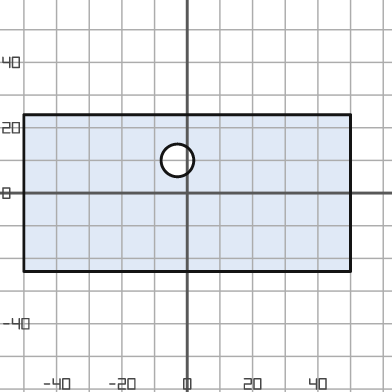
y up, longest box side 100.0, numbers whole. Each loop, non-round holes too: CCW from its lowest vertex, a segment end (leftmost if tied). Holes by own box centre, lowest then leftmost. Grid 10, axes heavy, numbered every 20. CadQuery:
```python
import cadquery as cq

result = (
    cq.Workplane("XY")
    .moveTo(-50.0, -24.0)
    .lineTo(50.0, -24.0)
    .lineTo(50.0, 24.0)
    .lineTo(-50.0, 24.0)
    .close()
    .moveTo(-3.0, 10.0)
    .circle(5.0)
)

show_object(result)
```